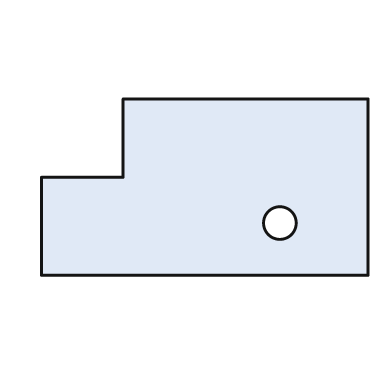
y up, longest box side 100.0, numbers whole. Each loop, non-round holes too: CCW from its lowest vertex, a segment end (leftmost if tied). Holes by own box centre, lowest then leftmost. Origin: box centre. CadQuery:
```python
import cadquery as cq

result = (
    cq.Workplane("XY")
    .moveTo(-50.0, -27.0)
    .lineTo(50.0, -27.0)
    .lineTo(50.0, 27.0)
    .lineTo(-25.0, 27.0)
    .lineTo(-25.0, 3.0)
    .lineTo(-50.0, 3.0)
    .close()
    .moveTo(23.0, -11.0)
    .circle(5.0)
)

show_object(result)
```